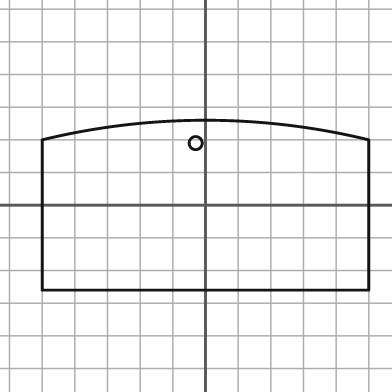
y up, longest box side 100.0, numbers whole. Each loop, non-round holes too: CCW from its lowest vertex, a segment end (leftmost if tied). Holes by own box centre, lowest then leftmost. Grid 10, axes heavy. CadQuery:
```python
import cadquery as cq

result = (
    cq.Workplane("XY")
    .moveTo(-50.0, -26.0)
    .lineTo(50.0, -26.0)
    .lineTo(50.0, 20.0)
    .threePointArc((0.0, 26.0), (-50.0, 20.0))
    .close()
    .moveTo(-3.0, 19.0)
    .circle(2.0)
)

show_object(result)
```